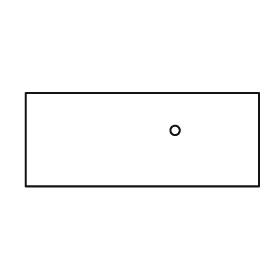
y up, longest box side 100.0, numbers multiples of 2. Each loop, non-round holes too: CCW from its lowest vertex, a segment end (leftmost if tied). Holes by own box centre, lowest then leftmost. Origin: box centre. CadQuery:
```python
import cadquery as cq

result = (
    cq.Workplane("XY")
    .moveTo(-50.0, -20.0)
    .lineTo(50.0, -20.0)
    .lineTo(50.0, 20.0)
    .lineTo(-50.0, 20.0)
    .close()
    .moveTo(14.0, 4.0)
    .circle(2.0)
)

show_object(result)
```